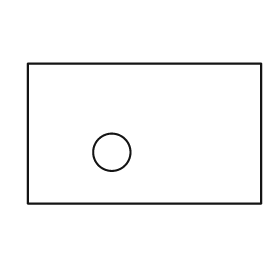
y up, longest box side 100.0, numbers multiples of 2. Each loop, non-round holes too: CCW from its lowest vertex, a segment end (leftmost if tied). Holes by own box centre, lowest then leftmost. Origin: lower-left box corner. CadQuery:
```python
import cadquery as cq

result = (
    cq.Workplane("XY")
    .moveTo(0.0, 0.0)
    .lineTo(100.0, 0.0)
    .lineTo(100.0, 60.0)
    .lineTo(0.0, 60.0)
    .close()
    .moveTo(36.0, 22.0)
    .circle(8.0)
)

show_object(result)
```